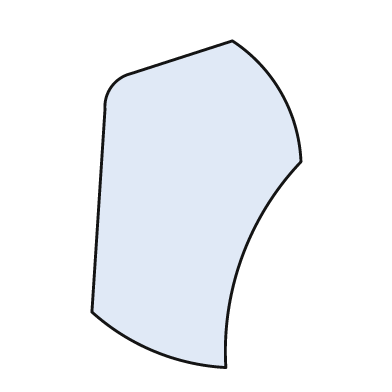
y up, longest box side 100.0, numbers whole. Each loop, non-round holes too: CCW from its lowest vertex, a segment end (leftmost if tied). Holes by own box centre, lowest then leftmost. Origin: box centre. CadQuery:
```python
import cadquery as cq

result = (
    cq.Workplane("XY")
    .moveTo(9.0, -50.0)
    .threePointArc((14.0, -16.0), (32.0, 13.0))
    .threePointArc((26.0, 34.0), (11.0, 50.0))
    .lineTo(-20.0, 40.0)
    .threePointArc((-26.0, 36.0), (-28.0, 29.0))
    .lineTo(-32.0, -33.0)
    .threePointArc((-13.0, -45.0), (9.0, -50.0))
    .close()
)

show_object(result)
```